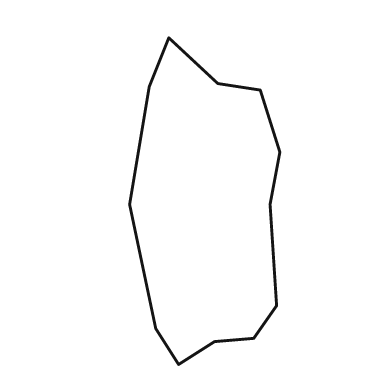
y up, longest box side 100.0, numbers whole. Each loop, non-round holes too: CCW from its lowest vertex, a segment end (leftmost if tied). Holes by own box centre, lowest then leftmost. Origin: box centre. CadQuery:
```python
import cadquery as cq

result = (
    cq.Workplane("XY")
    .moveTo(-8.0, -50.0)
    .lineTo(3.0, -43.0)
    .lineTo(15.0, -42.0)
    .lineTo(22.0, -32.0)
    .lineTo(20.0, -1.0)
    .lineTo(23.0, 15.0)
    .lineTo(17.0, 34.0)
    .lineTo(4.0, 36.0)
    .lineTo(-11.0, 50.0)
    .lineTo(-17.0, 35.0)
    .lineTo(-23.0, -1.0)
    .lineTo(-15.0, -39.0)
    .close()
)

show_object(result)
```